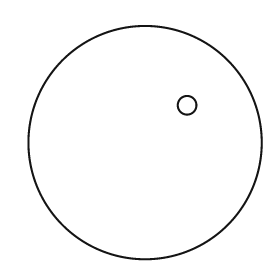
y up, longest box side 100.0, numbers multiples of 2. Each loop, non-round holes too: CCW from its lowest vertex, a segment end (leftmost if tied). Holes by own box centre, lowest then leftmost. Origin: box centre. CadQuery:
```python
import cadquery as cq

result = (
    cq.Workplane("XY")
    .moveTo(0.0, 0.0)
    .circle(50.0)
    .moveTo(18.0, 16.0)
    .circle(4.0)
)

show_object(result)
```